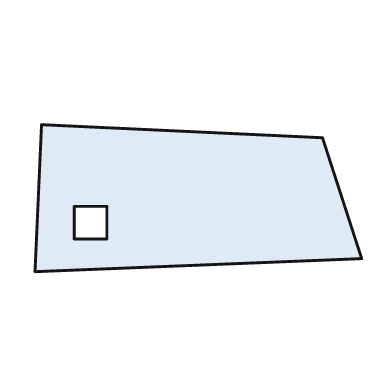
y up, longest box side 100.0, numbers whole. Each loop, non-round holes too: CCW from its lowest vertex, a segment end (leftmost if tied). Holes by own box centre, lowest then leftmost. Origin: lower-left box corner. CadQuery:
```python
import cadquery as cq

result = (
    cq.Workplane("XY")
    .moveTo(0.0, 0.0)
    .lineTo(100.0, 4.0)
    .lineTo(88.0, 41.0)
    .lineTo(2.0, 45.0)
    .close()
    .moveTo(12.0, 10.0)
    .lineTo(22.0, 10.0)
    .lineTo(22.0, 20.0)
    .lineTo(12.0, 20.0)
    .close()
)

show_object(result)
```